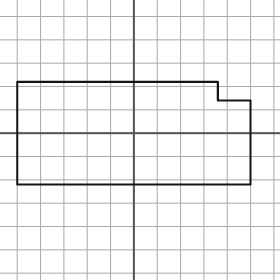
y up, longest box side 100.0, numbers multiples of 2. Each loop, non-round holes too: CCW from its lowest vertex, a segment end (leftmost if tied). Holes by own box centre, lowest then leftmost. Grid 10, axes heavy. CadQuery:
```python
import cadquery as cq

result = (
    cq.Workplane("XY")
    .moveTo(-50.0, -22.0)
    .lineTo(50.0, -22.0)
    .lineTo(50.0, 14.0)
    .lineTo(36.0, 14.0)
    .lineTo(36.0, 22.0)
    .lineTo(-50.0, 22.0)
    .close()
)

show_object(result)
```